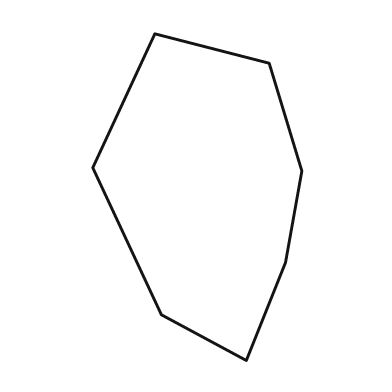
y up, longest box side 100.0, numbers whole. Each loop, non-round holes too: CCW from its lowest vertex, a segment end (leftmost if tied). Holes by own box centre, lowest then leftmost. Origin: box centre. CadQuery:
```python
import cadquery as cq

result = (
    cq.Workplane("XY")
    .moveTo(15.0, -50.0)
    .lineTo(27.0, -20.0)
    .lineTo(32.0, 8.0)
    .lineTo(22.0, 41.0)
    .lineTo(-13.0, 50.0)
    .lineTo(-32.0, 9.0)
    .lineTo(-11.0, -36.0)
    .close()
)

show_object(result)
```